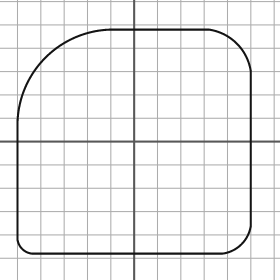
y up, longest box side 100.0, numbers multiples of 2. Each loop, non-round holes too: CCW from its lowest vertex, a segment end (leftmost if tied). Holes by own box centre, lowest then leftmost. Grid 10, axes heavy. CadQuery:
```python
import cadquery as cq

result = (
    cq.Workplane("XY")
    .moveTo(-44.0, -48.0)
    .lineTo(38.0, -48.0)
    .threePointArc((46.0, -44.0), (50.0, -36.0))
    .lineTo(50.0, 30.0)
    .threePointArc((44.0, 42.0), (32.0, 48.0))
    .lineTo(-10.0, 48.0)
    .threePointArc((-38.0, 36.0), (-50.0, 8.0))
    .lineTo(-50.0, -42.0)
    .threePointArc((-48.0, -46.0), (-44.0, -48.0))
    .close()
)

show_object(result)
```